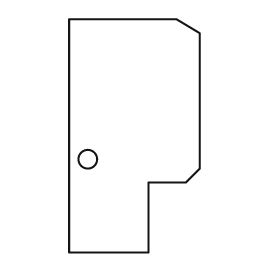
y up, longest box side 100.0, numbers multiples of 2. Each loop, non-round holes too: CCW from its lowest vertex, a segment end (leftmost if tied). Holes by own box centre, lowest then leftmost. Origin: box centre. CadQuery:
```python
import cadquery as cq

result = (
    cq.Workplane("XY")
    .moveTo(-28.0, -50.0)
    .lineTo(6.0, -50.0)
    .lineTo(6.0, -20.0)
    .lineTo(22.0, -20.0)
    .lineTo(28.0, -14.0)
    .lineTo(28.0, 44.0)
    .lineTo(18.0, 50.0)
    .lineTo(-28.0, 50.0)
    .close()
    .moveTo(-20.0, -10.0)
    .circle(4.0)
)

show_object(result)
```